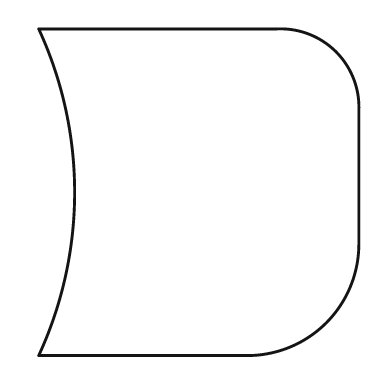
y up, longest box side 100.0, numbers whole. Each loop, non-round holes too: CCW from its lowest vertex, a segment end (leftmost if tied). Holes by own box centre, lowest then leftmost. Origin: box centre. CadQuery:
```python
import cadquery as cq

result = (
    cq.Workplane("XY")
    .moveTo(-49.0, -50.0)
    .lineTo(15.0, -50.0)
    .threePointArc((39.0, -40.0), (49.0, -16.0))
    .lineTo(49.0, 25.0)
    .threePointArc((42.0, 43.0), (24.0, 50.0))
    .lineTo(-49.0, 50.0)
    .threePointArc((-38.0, 0.0), (-49.0, -50.0))
    .close()
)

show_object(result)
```